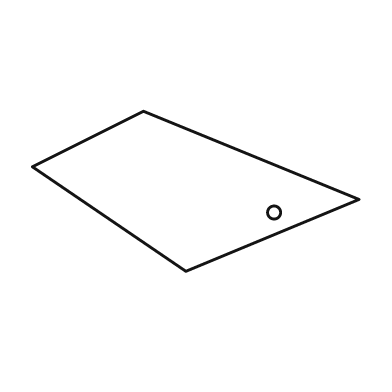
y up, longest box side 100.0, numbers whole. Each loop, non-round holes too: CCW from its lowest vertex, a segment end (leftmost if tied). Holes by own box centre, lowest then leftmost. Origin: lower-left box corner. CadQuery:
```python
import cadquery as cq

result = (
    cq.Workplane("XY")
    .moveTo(47.0, 0.0)
    .lineTo(100.0, 22.0)
    .lineTo(34.0, 49.0)
    .lineTo(0.0, 32.0)
    .close()
    .moveTo(74.0, 18.0)
    .circle(2.0)
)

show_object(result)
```